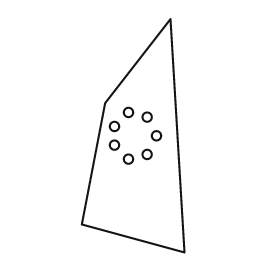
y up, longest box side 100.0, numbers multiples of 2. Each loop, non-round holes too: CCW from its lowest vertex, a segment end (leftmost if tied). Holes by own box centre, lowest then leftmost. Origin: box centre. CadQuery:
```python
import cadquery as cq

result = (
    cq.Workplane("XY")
    .moveTo(22.0, -50.0)
    .lineTo(16.0, 50.0)
    .lineTo(-12.0, 14.0)
    .lineTo(-22.0, -38.0)
    .close()
    .moveTo(-2.0, -10.0)
    .circle(2.0)
    .moveTo(6.0, -8.0)
    .circle(2.0)
    .moveTo(-8.0, -4.0)
    .circle(2.0)
    .moveTo(10.0, 0.0)
    .circle(2.0)
    .moveTo(-8.0, 4.0)
    .circle(2.0)
    .moveTo(6.0, 8.0)
    .circle(2.0)
    .moveTo(-2.0, 10.0)
    .circle(2.0)
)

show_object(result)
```